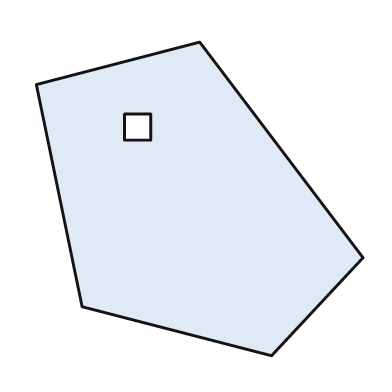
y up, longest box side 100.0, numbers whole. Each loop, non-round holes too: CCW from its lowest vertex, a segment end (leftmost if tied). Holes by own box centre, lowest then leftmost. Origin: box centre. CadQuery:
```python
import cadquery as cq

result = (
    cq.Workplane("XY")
    .moveTo(22.0, -48.0)
    .lineTo(50.0, -18.0)
    .lineTo(0.0, 48.0)
    .lineTo(-50.0, 35.0)
    .lineTo(-36.0, -33.0)
    .close()
    .moveTo(-23.0, 18.0)
    .lineTo(-15.0, 18.0)
    .lineTo(-15.0, 26.0)
    .lineTo(-23.0, 26.0)
    .close()
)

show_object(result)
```